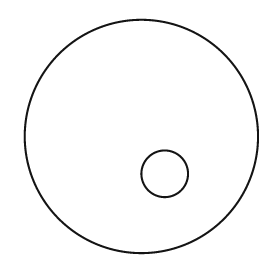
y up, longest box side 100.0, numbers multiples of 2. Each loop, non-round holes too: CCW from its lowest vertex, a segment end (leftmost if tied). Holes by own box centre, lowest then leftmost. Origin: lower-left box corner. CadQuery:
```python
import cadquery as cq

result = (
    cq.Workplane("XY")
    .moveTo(50.0, 50.0)
    .circle(50.0)
    .moveTo(60.0, 34.0)
    .circle(10.0)
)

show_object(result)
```